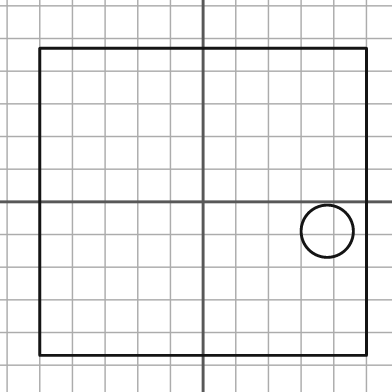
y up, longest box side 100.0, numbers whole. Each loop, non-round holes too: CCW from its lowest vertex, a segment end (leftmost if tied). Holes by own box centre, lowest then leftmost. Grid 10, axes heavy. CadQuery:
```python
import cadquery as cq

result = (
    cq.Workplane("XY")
    .moveTo(-50.0, -47.0)
    .lineTo(50.0, -47.0)
    .lineTo(50.0, 47.0)
    .lineTo(-50.0, 47.0)
    .close()
    .moveTo(38.0, -9.0)
    .circle(8.0)
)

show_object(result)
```